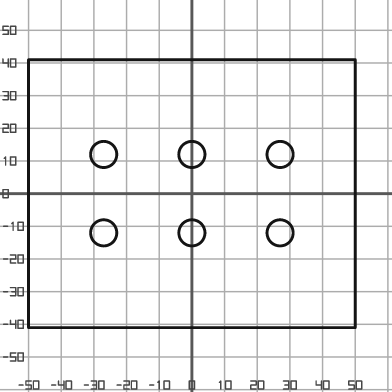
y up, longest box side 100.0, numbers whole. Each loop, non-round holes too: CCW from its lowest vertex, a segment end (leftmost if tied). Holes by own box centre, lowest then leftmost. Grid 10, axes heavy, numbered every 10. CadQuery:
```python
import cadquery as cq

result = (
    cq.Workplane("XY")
    .moveTo(-50.0, -41.0)
    .lineTo(50.0, -41.0)
    .lineTo(50.0, 41.0)
    .lineTo(-50.0, 41.0)
    .close()
    .moveTo(-27.0, -12.0)
    .circle(4.0)
    .moveTo(0.0, -12.0)
    .circle(4.0)
    .moveTo(27.0, -12.0)
    .circle(4.0)
    .moveTo(-27.0, 12.0)
    .circle(4.0)
    .moveTo(0.0, 12.0)
    .circle(4.0)
    .moveTo(27.0, 12.0)
    .circle(4.0)
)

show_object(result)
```